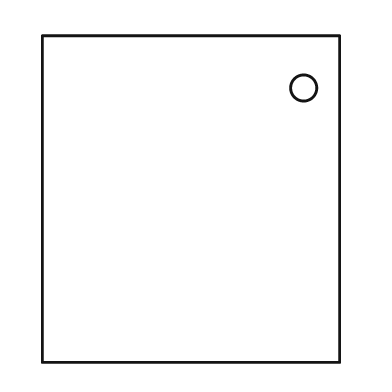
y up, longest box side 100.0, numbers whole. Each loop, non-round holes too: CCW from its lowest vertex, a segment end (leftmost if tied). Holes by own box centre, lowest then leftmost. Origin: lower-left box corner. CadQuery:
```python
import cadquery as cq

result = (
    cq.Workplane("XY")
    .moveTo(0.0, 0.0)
    .lineTo(91.0, 0.0)
    .lineTo(91.0, 100.0)
    .lineTo(0.0, 100.0)
    .close()
    .moveTo(80.0, 84.0)
    .circle(4.0)
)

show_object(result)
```